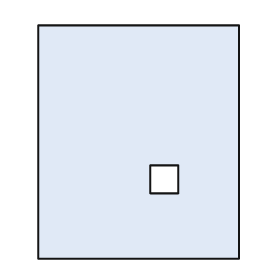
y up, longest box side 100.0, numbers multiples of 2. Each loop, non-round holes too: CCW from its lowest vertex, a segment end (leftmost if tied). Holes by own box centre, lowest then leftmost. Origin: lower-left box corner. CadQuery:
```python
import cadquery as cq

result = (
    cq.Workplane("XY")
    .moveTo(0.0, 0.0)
    .lineTo(86.0, 0.0)
    .lineTo(86.0, 100.0)
    .lineTo(0.0, 100.0)
    .close()
    .moveTo(48.0, 28.0)
    .lineTo(60.0, 28.0)
    .lineTo(60.0, 40.0)
    .lineTo(48.0, 40.0)
    .close()
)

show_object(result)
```